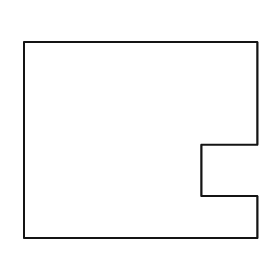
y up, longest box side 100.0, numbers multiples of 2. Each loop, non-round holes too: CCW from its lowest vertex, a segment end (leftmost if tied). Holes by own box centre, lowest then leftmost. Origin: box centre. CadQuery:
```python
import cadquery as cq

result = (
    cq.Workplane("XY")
    .moveTo(-50.0, -42.0)
    .lineTo(50.0, -42.0)
    .lineTo(50.0, -24.0)
    .lineTo(26.0, -24.0)
    .lineTo(26.0, -2.0)
    .lineTo(50.0, -2.0)
    .lineTo(50.0, 42.0)
    .lineTo(-50.0, 42.0)
    .close()
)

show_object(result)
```